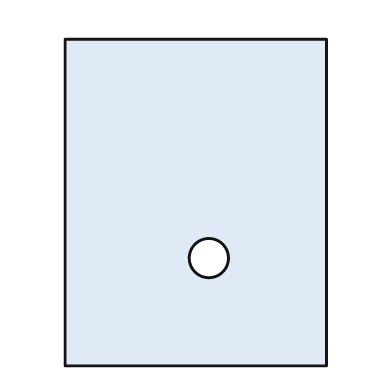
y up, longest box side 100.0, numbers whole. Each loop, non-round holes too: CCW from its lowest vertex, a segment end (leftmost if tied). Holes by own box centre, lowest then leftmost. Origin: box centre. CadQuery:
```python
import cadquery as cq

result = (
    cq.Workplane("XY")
    .moveTo(-40.0, -50.0)
    .lineTo(40.0, -50.0)
    .lineTo(40.0, 50.0)
    .lineTo(-40.0, 50.0)
    .close()
    .moveTo(4.0, -17.0)
    .circle(6.0)
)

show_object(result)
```